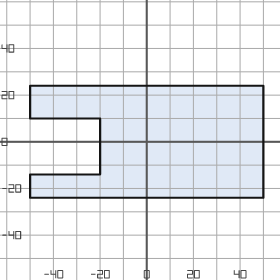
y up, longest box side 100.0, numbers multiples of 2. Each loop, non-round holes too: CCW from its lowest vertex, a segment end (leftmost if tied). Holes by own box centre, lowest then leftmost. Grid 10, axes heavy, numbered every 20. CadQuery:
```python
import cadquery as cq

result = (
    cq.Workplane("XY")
    .moveTo(-50.0, -24.0)
    .lineTo(50.0, -24.0)
    .lineTo(50.0, 24.0)
    .lineTo(-50.0, 24.0)
    .lineTo(-50.0, 10.0)
    .lineTo(-20.0, 10.0)
    .lineTo(-20.0, -14.0)
    .lineTo(-50.0, -14.0)
    .close()
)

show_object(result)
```